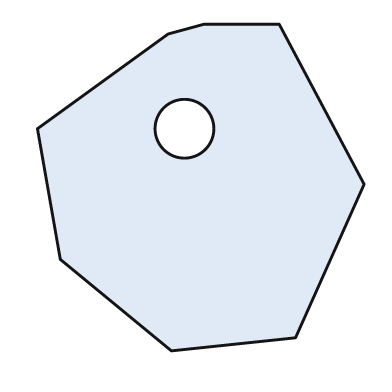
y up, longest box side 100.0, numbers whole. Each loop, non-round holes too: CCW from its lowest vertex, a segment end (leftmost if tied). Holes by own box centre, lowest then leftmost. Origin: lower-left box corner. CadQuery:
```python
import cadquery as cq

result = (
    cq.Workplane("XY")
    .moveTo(41.0, 0.0)
    .lineTo(79.0, 4.0)
    .lineTo(100.0, 51.0)
    .lineTo(74.0, 100.0)
    .lineTo(51.0, 100.0)
    .lineTo(40.0, 97.0)
    .lineTo(0.0, 68.0)
    .lineTo(7.0, 28.0)
    .close()
    .moveTo(45.0, 68.0)
    .circle(9.0)
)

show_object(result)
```